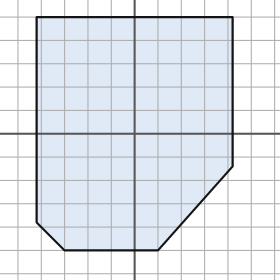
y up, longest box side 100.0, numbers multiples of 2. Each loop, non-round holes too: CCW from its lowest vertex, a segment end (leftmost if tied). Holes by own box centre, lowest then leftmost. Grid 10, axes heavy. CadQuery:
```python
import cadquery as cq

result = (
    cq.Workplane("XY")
    .moveTo(-30.0, -50.0)
    .lineTo(10.0, -50.0)
    .lineTo(42.0, -14.0)
    .lineTo(42.0, 50.0)
    .lineTo(-42.0, 50.0)
    .lineTo(-42.0, -38.0)
    .close()
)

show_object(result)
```